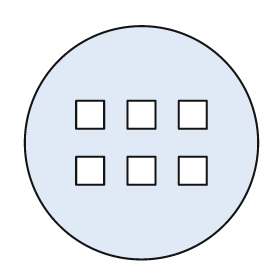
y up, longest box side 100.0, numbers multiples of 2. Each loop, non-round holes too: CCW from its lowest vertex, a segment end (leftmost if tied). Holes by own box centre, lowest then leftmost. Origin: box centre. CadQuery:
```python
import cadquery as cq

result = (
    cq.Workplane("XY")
    .moveTo(0.0, 0.0)
    .circle(50.0)
    .moveTo(-28.0, -18.0)
    .lineTo(-16.0, -18.0)
    .lineTo(-16.0, -6.0)
    .lineTo(-28.0, -6.0)
    .close()
    .moveTo(-6.0, -18.0)
    .lineTo(6.0, -18.0)
    .lineTo(6.0, -6.0)
    .lineTo(-6.0, -6.0)
    .close()
    .moveTo(16.0, -18.0)
    .lineTo(28.0, -18.0)
    .lineTo(28.0, -6.0)
    .lineTo(16.0, -6.0)
    .close()
    .moveTo(-28.0, 6.0)
    .lineTo(-16.0, 6.0)
    .lineTo(-16.0, 18.0)
    .lineTo(-28.0, 18.0)
    .close()
    .moveTo(-6.0, 6.0)
    .lineTo(6.0, 6.0)
    .lineTo(6.0, 18.0)
    .lineTo(-6.0, 18.0)
    .close()
    .moveTo(16.0, 6.0)
    .lineTo(28.0, 6.0)
    .lineTo(28.0, 18.0)
    .lineTo(16.0, 18.0)
    .close()
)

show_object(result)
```